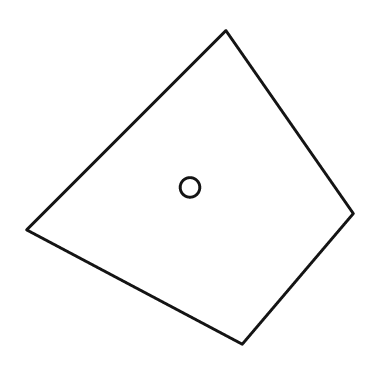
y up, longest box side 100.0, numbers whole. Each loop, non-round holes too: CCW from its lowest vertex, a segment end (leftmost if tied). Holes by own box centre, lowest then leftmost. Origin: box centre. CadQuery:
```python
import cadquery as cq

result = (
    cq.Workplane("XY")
    .moveTo(16.0, -48.0)
    .lineTo(50.0, -8.0)
    .lineTo(11.0, 48.0)
    .lineTo(-50.0, -13.0)
    .close()
    .moveTo(0.0, 0.0)
    .circle(3.0)
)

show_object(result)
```